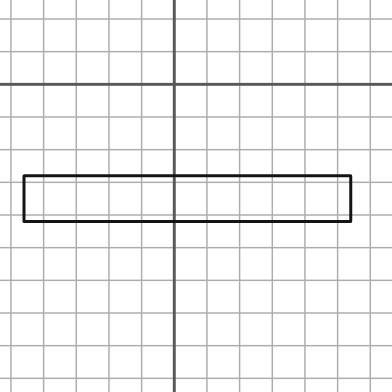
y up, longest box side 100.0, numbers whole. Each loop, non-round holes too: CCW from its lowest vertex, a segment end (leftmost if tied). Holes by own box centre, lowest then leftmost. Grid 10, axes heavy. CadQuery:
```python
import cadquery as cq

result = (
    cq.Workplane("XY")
    .moveTo(-46.0, -42.0)
    .lineTo(54.0, -42.0)
    .lineTo(54.0, -28.0)
    .lineTo(-46.0, -28.0)
    .close()
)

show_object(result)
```